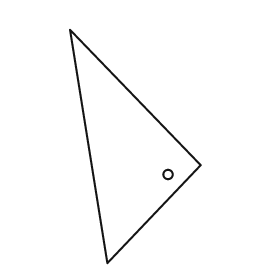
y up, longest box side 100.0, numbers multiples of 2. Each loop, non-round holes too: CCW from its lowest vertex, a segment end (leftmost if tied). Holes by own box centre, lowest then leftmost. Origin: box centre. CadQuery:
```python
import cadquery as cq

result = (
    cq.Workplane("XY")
    .moveTo(-12.0, -50.0)
    .lineTo(28.0, -8.0)
    .lineTo(-28.0, 50.0)
    .close()
    .moveTo(14.0, -12.0)
    .circle(2.0)
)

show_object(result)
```